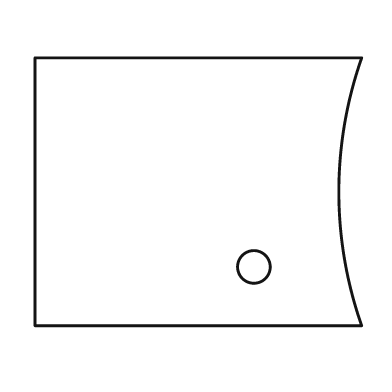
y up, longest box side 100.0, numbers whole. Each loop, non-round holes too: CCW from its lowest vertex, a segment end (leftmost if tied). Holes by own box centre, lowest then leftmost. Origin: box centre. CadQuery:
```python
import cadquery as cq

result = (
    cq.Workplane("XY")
    .moveTo(-50.0, -41.0)
    .lineTo(50.0, -41.0)
    .threePointArc((43.0, 0.0), (50.0, 41.0))
    .lineTo(-50.0, 41.0)
    .close()
    .moveTo(17.0, -23.0)
    .circle(5.0)
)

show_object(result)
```